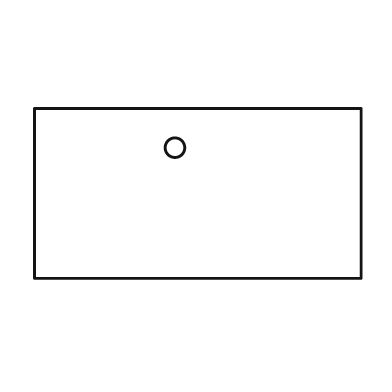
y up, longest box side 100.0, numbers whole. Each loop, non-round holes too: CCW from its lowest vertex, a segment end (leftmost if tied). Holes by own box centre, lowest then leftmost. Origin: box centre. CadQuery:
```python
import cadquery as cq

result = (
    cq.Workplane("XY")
    .moveTo(-50.0, -26.0)
    .lineTo(50.0, -26.0)
    .lineTo(50.0, 26.0)
    .lineTo(-50.0, 26.0)
    .close()
    .moveTo(-7.0, 14.0)
    .circle(3.0)
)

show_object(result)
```